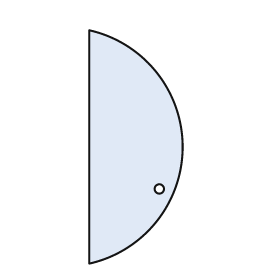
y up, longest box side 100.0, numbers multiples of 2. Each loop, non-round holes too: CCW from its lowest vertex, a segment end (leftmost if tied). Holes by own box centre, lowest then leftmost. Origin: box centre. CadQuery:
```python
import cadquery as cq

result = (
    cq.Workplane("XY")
    .moveTo(-20.0, -50.0)
    .threePointArc((20.0, 0.0), (-20.0, 50.0))
    .close()
    .moveTo(10.0, -18.0)
    .circle(2.0)
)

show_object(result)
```